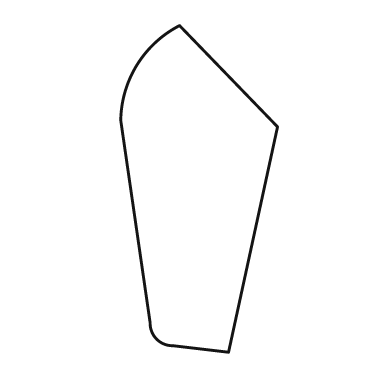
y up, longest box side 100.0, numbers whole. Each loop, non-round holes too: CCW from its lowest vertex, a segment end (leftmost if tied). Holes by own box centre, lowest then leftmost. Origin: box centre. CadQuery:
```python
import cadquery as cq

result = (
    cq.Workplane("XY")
    .moveTo(9.0, -50.0)
    .lineTo(24.0, 19.0)
    .lineTo(-6.0, 50.0)
    .threePointArc((-19.0, 38.0), (-24.0, 21.0))
    .lineTo(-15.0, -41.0)
    .threePointArc((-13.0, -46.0), (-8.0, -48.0))
    .close()
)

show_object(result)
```